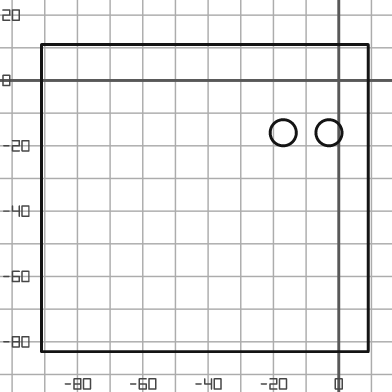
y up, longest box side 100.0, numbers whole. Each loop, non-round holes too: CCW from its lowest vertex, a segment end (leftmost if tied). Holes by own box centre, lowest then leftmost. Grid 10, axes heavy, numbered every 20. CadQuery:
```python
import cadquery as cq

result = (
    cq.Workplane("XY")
    .moveTo(-91.0, -83.0)
    .lineTo(9.0, -83.0)
    .lineTo(9.0, 11.0)
    .lineTo(-91.0, 11.0)
    .close()
    .moveTo(-17.0, -16.0)
    .circle(4.0)
    .moveTo(-3.0, -16.0)
    .circle(4.0)
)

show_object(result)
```